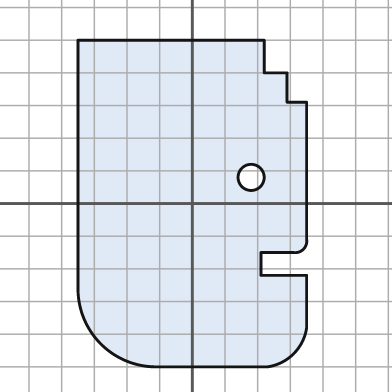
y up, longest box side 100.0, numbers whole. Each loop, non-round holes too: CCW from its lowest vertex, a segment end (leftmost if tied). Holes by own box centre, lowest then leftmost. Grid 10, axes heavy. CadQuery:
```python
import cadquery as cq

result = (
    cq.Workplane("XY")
    .moveTo(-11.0, -50.0)
    .lineTo(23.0, -50.0)
    .threePointArc((31.0, -46.0), (35.0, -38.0))
    .lineTo(35.0, -22.0)
    .lineTo(21.0, -22.0)
    .lineTo(21.0, -15.0)
    .lineTo(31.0, -15.0)
    .threePointArc((34.0, -14.0), (35.0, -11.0))
    .lineTo(35.0, 31.0)
    .lineTo(29.0, 31.0)
    .lineTo(29.0, 40.0)
    .lineTo(22.0, 40.0)
    .lineTo(22.0, 50.0)
    .lineTo(-35.0, 50.0)
    .lineTo(-35.0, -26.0)
    .threePointArc((-28.0, -43.0), (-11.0, -50.0))
    .close()
    .moveTo(18.0, 8.0)
    .circle(4.0)
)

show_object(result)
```